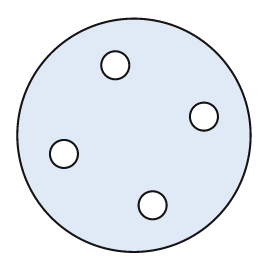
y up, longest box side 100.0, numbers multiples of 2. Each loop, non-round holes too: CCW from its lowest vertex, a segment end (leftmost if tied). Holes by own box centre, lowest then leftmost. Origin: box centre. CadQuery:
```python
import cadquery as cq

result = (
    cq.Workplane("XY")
    .moveTo(0.0, 0.0)
    .circle(50.0)
    .moveTo(8.0, -30.0)
    .circle(6.0)
    .moveTo(-30.0, -8.0)
    .circle(6.0)
    .moveTo(30.0, 8.0)
    .circle(6.0)
    .moveTo(-8.0, 30.0)
    .circle(6.0)
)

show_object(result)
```